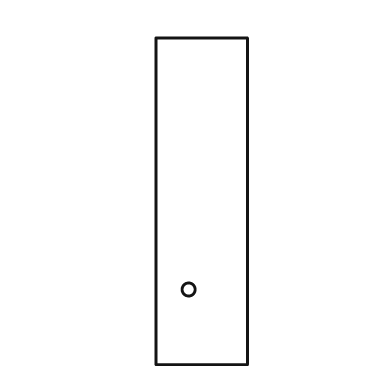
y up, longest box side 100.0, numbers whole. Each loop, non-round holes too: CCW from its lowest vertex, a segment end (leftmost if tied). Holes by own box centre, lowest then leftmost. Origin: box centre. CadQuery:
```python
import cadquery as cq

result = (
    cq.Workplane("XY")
    .moveTo(-14.0, -50.0)
    .lineTo(14.0, -50.0)
    .lineTo(14.0, 50.0)
    .lineTo(-14.0, 50.0)
    .close()
    .moveTo(-4.0, -27.0)
    .circle(2.0)
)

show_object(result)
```